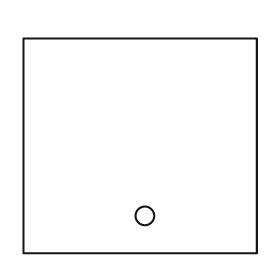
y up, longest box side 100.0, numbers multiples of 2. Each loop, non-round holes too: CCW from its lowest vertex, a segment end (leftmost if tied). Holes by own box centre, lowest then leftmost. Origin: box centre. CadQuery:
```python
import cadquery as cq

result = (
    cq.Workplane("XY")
    .moveTo(-50.0, -46.0)
    .lineTo(50.0, -46.0)
    .lineTo(50.0, 46.0)
    .lineTo(-50.0, 46.0)
    .close()
    .moveTo(2.0, -30.0)
    .circle(4.0)
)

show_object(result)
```